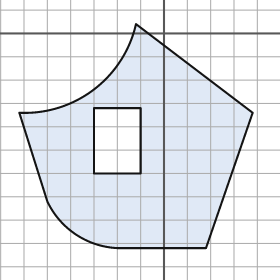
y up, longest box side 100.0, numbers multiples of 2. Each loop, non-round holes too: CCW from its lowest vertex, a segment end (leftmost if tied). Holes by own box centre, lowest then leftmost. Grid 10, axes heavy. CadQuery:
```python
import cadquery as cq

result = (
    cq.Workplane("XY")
    .moveTo(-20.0, -92.0)
    .lineTo(18.0, -92.0)
    .lineTo(38.0, -34.0)
    .lineTo(-12.0, 4.0)
    .threePointArc((-30.0, -24.0), (-62.0, -34.0))
    .lineTo(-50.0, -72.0)
    .threePointArc((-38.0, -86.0), (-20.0, -92.0))
    .close()
    .moveTo(-30.0, -60.0)
    .lineTo(-10.0, -60.0)
    .lineTo(-10.0, -32.0)
    .lineTo(-30.0, -32.0)
    .close()
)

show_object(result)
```